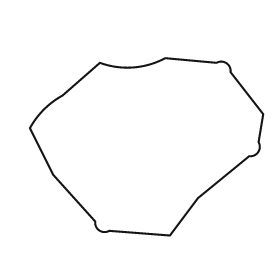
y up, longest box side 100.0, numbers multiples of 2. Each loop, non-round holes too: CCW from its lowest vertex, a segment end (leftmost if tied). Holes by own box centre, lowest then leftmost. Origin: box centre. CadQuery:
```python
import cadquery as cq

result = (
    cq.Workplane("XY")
    .moveTo(10.0, -38.0)
    .lineTo(22.0, -22.0)
    .lineTo(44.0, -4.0)
    .threePointArc((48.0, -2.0), (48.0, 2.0))
    .lineTo(50.0, 14.0)
    .lineTo(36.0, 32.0)
    .threePointArc((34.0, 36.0), (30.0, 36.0))
    .lineTo(8.0, 38.0)
    .threePointArc((-6.0, 34.0), (-20.0, 36.0))
    .lineTo(-36.0, 22.0)
    .threePointArc((-44.0, 16.0), (-50.0, 8.0))
    .lineTo(-40.0, -12.0)
    .lineTo(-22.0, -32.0)
    .threePointArc((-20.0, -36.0), (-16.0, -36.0))
    .close()
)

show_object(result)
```